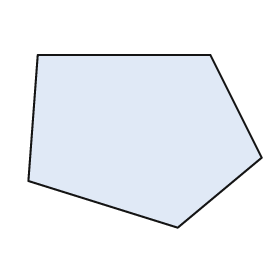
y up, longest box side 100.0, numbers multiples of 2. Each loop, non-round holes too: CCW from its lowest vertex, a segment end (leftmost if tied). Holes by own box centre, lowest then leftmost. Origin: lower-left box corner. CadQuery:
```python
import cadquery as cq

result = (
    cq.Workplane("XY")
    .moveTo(64.0, 0.0)
    .lineTo(100.0, 30.0)
    .lineTo(78.0, 74.0)
    .lineTo(4.0, 74.0)
    .lineTo(0.0, 20.0)
    .close()
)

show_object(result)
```